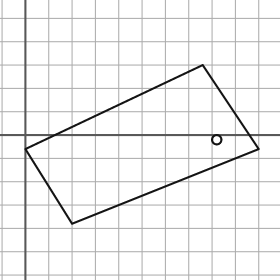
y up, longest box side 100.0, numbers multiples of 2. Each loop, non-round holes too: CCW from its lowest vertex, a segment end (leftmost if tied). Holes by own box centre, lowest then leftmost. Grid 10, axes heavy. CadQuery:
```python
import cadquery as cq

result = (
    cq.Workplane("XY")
    .moveTo(20.0, -38.0)
    .lineTo(100.0, -6.0)
    .lineTo(76.0, 30.0)
    .lineTo(0.0, -6.0)
    .close()
    .moveTo(82.0, -2.0)
    .circle(2.0)
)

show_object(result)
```